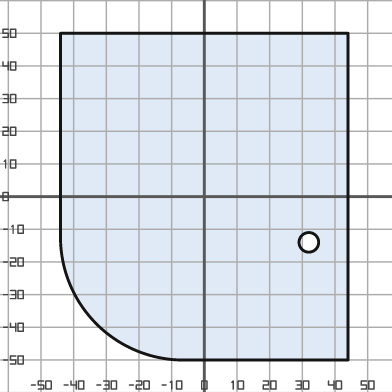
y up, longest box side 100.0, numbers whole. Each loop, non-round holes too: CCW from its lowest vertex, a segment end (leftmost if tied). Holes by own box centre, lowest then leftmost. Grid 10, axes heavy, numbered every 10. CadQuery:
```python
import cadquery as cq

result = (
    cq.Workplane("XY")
    .moveTo(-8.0, -50.0)
    .lineTo(44.0, -50.0)
    .lineTo(44.0, 50.0)
    .lineTo(-44.0, 50.0)
    .lineTo(-44.0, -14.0)
    .threePointArc((-33.0, -39.0), (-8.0, -50.0))
    .close()
    .moveTo(32.0, -14.0)
    .circle(3.0)
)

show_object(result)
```